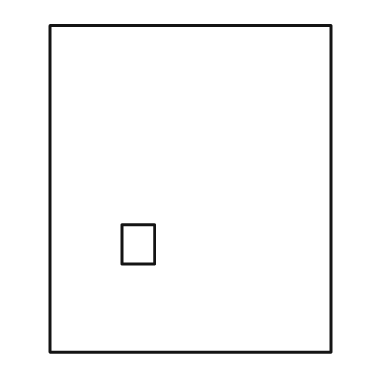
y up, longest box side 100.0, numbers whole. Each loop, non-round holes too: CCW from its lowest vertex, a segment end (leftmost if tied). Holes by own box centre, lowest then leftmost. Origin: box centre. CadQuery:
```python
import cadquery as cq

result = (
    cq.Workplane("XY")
    .moveTo(-43.0, -50.0)
    .lineTo(43.0, -50.0)
    .lineTo(43.0, 50.0)
    .lineTo(-43.0, 50.0)
    .close()
    .moveTo(-21.0, -23.0)
    .lineTo(-11.0, -23.0)
    .lineTo(-11.0, -11.0)
    .lineTo(-21.0, -11.0)
    .close()
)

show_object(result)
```